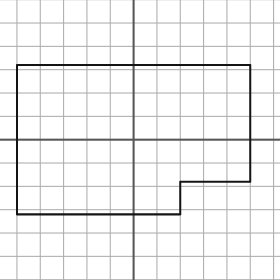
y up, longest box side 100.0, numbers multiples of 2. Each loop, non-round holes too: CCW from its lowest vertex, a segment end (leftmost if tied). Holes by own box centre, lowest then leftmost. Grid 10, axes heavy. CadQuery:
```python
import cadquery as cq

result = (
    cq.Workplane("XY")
    .moveTo(-50.0, -32.0)
    .lineTo(20.0, -32.0)
    .lineTo(20.0, -18.0)
    .lineTo(50.0, -18.0)
    .lineTo(50.0, 32.0)
    .lineTo(-50.0, 32.0)
    .close()
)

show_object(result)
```